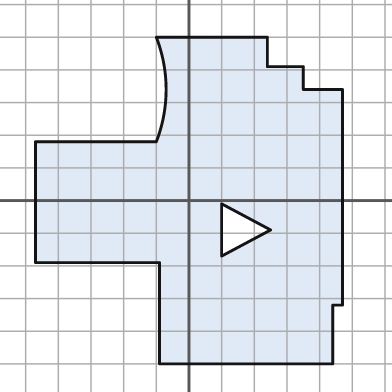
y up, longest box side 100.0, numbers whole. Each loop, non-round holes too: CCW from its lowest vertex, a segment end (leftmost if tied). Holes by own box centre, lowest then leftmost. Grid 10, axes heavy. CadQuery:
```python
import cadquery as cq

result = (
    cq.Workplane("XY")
    .moveTo(-9.0, -50.0)
    .lineTo(44.0, -50.0)
    .lineTo(44.0, -32.0)
    .lineTo(47.0, -32.0)
    .lineTo(47.0, 34.0)
    .lineTo(35.0, 34.0)
    .lineTo(35.0, 41.0)
    .lineTo(24.0, 41.0)
    .lineTo(24.0, 50.0)
    .lineTo(-10.0, 50.0)
    .threePointArc((-7.0, 34.0), (-10.0, 18.0))
    .lineTo(-47.0, 18.0)
    .lineTo(-47.0, -19.0)
    .lineTo(-9.0, -19.0)
    .close()
    .moveTo(10.0, -17.0)
    .lineTo(25.0, -9.0)
    .lineTo(10.0, -1.0)
    .close()
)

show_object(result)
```